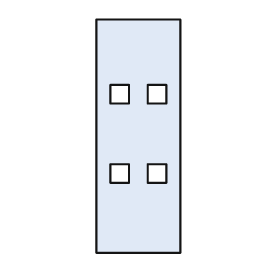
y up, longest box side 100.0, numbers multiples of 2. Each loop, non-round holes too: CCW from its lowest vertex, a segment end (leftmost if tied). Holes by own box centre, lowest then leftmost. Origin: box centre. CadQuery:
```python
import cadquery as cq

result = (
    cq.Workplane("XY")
    .moveTo(-18.0, -50.0)
    .lineTo(18.0, -50.0)
    .lineTo(18.0, 50.0)
    .lineTo(-18.0, 50.0)
    .close()
    .moveTo(-12.0, -20.0)
    .lineTo(-4.0, -20.0)
    .lineTo(-4.0, -12.0)
    .lineTo(-12.0, -12.0)
    .close()
    .moveTo(4.0, -20.0)
    .lineTo(12.0, -20.0)
    .lineTo(12.0, -12.0)
    .lineTo(4.0, -12.0)
    .close()
    .moveTo(-12.0, 14.0)
    .lineTo(-4.0, 14.0)
    .lineTo(-4.0, 22.0)
    .lineTo(-12.0, 22.0)
    .close()
    .moveTo(4.0, 14.0)
    .lineTo(12.0, 14.0)
    .lineTo(12.0, 22.0)
    .lineTo(4.0, 22.0)
    .close()
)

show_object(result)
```